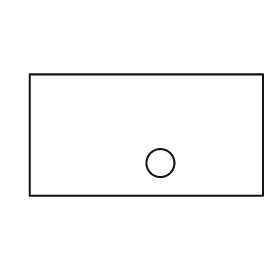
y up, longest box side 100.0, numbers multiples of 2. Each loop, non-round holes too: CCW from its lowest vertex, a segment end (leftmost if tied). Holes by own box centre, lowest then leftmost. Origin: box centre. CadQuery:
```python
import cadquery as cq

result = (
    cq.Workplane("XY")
    .moveTo(-50.0, -26.0)
    .lineTo(50.0, -26.0)
    .lineTo(50.0, 26.0)
    .lineTo(-50.0, 26.0)
    .close()
    .moveTo(6.0, -12.0)
    .circle(6.0)
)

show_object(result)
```